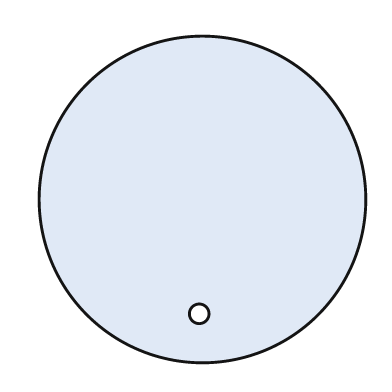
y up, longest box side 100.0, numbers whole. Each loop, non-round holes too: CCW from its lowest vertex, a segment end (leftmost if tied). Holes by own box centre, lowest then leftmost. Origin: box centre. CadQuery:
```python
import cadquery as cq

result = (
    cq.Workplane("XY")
    .moveTo(0.0, 0.0)
    .circle(50.0)
    .moveTo(-1.0, -35.0)
    .circle(3.0)
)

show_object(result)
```